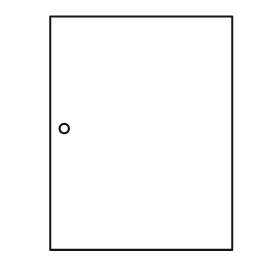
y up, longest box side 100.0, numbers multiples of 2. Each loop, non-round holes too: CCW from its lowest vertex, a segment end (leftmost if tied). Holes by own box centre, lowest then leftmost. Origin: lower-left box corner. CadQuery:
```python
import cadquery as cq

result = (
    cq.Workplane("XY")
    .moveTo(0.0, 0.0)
    .lineTo(78.0, 0.0)
    .lineTo(78.0, 100.0)
    .lineTo(0.0, 100.0)
    .close()
    .moveTo(6.0, 52.0)
    .circle(2.0)
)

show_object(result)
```